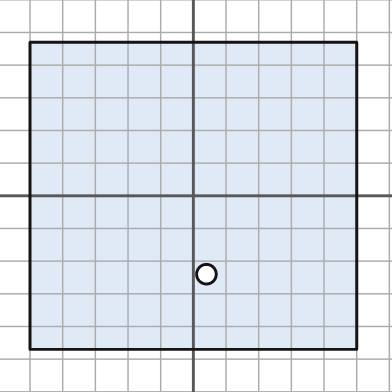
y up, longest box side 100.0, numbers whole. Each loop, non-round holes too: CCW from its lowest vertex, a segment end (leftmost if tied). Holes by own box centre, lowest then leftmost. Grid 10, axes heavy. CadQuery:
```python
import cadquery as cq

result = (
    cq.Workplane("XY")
    .moveTo(-50.0, -47.0)
    .lineTo(50.0, -47.0)
    .lineTo(50.0, 47.0)
    .lineTo(-50.0, 47.0)
    .close()
    .moveTo(4.0, -24.0)
    .circle(3.0)
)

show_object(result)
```